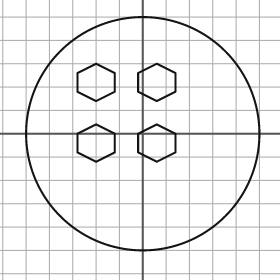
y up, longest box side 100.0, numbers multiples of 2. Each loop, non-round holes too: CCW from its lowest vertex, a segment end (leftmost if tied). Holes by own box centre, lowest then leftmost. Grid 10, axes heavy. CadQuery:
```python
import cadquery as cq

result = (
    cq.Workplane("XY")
    .moveTo(0.0, 0.0)
    .circle(50.0)
    .moveTo(-20.0, -12.0)
    .lineTo(-12.0, -8.0)
    .lineTo(-12.0, 0.0)
    .lineTo(-20.0, 4.0)
    .lineTo(-28.0, 0.0)
    .lineTo(-28.0, -8.0)
    .close()
    .moveTo(6.0, -12.0)
    .lineTo(14.0, -8.0)
    .lineTo(14.0, 0.0)
    .lineTo(6.0, 4.0)
    .lineTo(-2.0, 0.0)
    .lineTo(-2.0, -8.0)
    .close()
    .moveTo(-20.0, 14.0)
    .lineTo(-12.0, 18.0)
    .lineTo(-12.0, 26.0)
    .lineTo(-20.0, 30.0)
    .lineTo(-28.0, 26.0)
    .lineTo(-28.0, 18.0)
    .close()
    .moveTo(6.0, 14.0)
    .lineTo(14.0, 18.0)
    .lineTo(14.0, 26.0)
    .lineTo(6.0, 30.0)
    .lineTo(-2.0, 26.0)
    .lineTo(-2.0, 18.0)
    .close()
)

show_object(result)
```